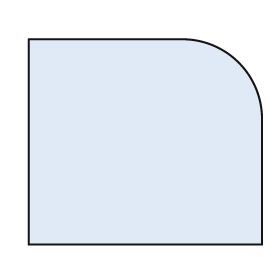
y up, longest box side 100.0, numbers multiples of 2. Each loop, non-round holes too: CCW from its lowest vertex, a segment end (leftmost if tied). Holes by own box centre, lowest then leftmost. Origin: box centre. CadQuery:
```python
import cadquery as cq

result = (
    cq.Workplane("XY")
    .moveTo(-50.0, -44.0)
    .lineTo(50.0, -44.0)
    .lineTo(50.0, 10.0)
    .threePointArc((40.0, 34.0), (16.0, 44.0))
    .lineTo(-50.0, 44.0)
    .close()
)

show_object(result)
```